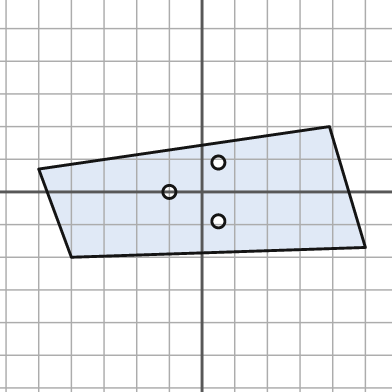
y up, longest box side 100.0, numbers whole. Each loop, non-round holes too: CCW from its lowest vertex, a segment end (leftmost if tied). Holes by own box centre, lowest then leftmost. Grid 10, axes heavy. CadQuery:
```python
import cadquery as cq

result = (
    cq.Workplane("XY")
    .moveTo(-40.0, -20.0)
    .lineTo(50.0, -17.0)
    .lineTo(39.0, 20.0)
    .lineTo(-50.0, 7.0)
    .close()
    .moveTo(5.0, -9.0)
    .circle(2.0)
    .moveTo(-10.0, 0.0)
    .circle(2.0)
    .moveTo(5.0, 9.0)
    .circle(2.0)
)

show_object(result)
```